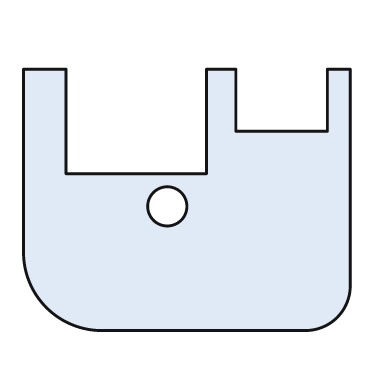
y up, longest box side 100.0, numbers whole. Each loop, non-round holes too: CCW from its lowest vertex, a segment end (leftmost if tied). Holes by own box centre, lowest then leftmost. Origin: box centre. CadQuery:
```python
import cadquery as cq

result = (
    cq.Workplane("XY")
    .moveTo(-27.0, -40.0)
    .lineTo(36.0, -40.0)
    .threePointArc((46.0, -36.0), (50.0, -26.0))
    .lineTo(50.0, 40.0)
    .lineTo(43.0, 40.0)
    .lineTo(43.0, 21.0)
    .lineTo(15.0, 21.0)
    .lineTo(15.0, 40.0)
    .lineTo(6.0, 40.0)
    .lineTo(6.0, 8.0)
    .lineTo(-37.0, 8.0)
    .lineTo(-37.0, 40.0)
    .lineTo(-50.0, 40.0)
    .lineTo(-50.0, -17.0)
    .threePointArc((-43.0, -33.0), (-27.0, -40.0))
    .close()
    .moveTo(-6.0, -2.0)
    .circle(6.0)
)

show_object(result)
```